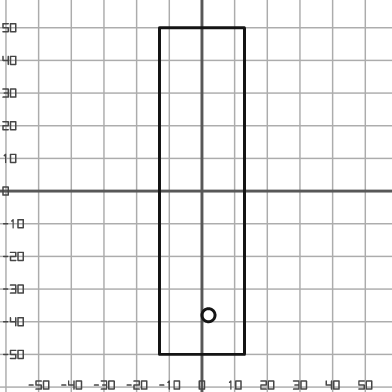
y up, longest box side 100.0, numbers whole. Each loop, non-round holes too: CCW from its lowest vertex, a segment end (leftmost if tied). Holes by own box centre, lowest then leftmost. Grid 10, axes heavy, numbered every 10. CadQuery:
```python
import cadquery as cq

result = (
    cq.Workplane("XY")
    .moveTo(-13.0, -50.0)
    .lineTo(13.0, -50.0)
    .lineTo(13.0, 50.0)
    .lineTo(-13.0, 50.0)
    .close()
    .moveTo(2.0, -38.0)
    .circle(2.0)
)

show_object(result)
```